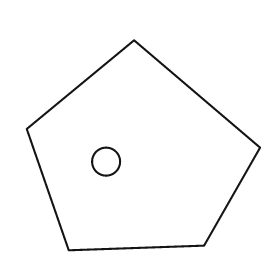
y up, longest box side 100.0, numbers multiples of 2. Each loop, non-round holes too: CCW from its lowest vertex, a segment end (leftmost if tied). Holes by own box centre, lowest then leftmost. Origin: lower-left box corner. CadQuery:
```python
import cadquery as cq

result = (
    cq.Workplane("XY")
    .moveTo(18.0, 0.0)
    .lineTo(76.0, 2.0)
    .lineTo(100.0, 44.0)
    .lineTo(46.0, 90.0)
    .lineTo(0.0, 52.0)
    .close()
    .moveTo(34.0, 38.0)
    .circle(6.0)
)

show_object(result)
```